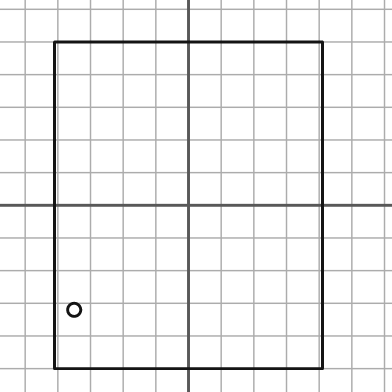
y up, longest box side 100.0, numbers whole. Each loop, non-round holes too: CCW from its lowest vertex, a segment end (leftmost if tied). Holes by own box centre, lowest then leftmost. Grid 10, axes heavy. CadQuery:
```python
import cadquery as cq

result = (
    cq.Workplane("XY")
    .moveTo(-41.0, -50.0)
    .lineTo(41.0, -50.0)
    .lineTo(41.0, 50.0)
    .lineTo(-41.0, 50.0)
    .close()
    .moveTo(-35.0, -32.0)
    .circle(2.0)
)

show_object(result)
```